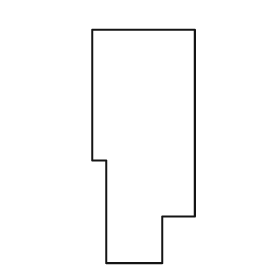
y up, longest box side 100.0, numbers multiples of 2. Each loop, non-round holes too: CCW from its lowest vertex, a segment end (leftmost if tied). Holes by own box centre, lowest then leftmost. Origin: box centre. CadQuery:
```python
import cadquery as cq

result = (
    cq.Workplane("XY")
    .moveTo(-16.0, -50.0)
    .lineTo(8.0, -50.0)
    .lineTo(8.0, -30.0)
    .lineTo(22.0, -30.0)
    .lineTo(22.0, 50.0)
    .lineTo(-22.0, 50.0)
    .lineTo(-22.0, -6.0)
    .lineTo(-16.0, -6.0)
    .close()
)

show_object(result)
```